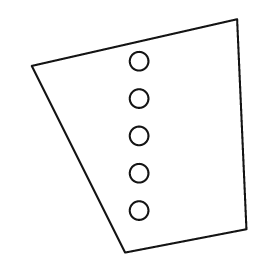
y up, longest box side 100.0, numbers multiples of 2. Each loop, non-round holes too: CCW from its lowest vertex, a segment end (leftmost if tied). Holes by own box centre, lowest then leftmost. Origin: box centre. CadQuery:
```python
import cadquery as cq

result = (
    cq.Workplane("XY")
    .moveTo(-6.0, -50.0)
    .lineTo(46.0, -40.0)
    .lineTo(42.0, 50.0)
    .lineTo(-46.0, 30.0)
    .close()
    .moveTo(0.0, -32.0)
    .circle(4.0)
    .moveTo(0.0, -16.0)
    .circle(4.0)
    .moveTo(0.0, 0.0)
    .circle(4.0)
    .moveTo(0.0, 16.0)
    .circle(4.0)
    .moveTo(0.0, 32.0)
    .circle(4.0)
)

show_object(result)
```